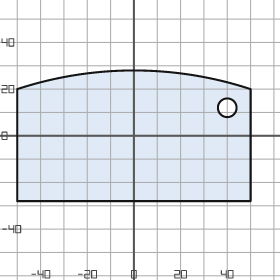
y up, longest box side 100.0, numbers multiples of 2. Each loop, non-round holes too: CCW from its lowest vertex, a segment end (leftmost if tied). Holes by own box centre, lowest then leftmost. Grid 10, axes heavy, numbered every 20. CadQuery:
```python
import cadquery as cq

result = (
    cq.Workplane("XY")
    .moveTo(-50.0, -28.0)
    .lineTo(50.0, -28.0)
    .lineTo(50.0, 20.0)
    .threePointArc((0.0, 28.0), (-50.0, 20.0))
    .close()
    .moveTo(40.0, 12.0)
    .circle(4.0)
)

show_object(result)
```